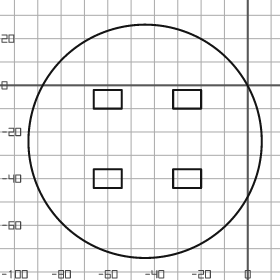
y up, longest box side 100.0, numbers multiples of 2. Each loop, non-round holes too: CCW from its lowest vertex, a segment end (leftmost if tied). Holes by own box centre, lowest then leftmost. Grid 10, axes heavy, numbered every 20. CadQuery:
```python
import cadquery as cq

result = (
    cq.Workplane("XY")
    .moveTo(-44.0, -24.0)
    .circle(50.0)
    .moveTo(-66.0, -44.0)
    .lineTo(-54.0, -44.0)
    .lineTo(-54.0, -36.0)
    .lineTo(-66.0, -36.0)
    .close()
    .moveTo(-32.0, -44.0)
    .lineTo(-20.0, -44.0)
    .lineTo(-20.0, -36.0)
    .lineTo(-32.0, -36.0)
    .close()
    .moveTo(-66.0, -10.0)
    .lineTo(-54.0, -10.0)
    .lineTo(-54.0, -2.0)
    .lineTo(-66.0, -2.0)
    .close()
    .moveTo(-32.0, -10.0)
    .lineTo(-20.0, -10.0)
    .lineTo(-20.0, -2.0)
    .lineTo(-32.0, -2.0)
    .close()
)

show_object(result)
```